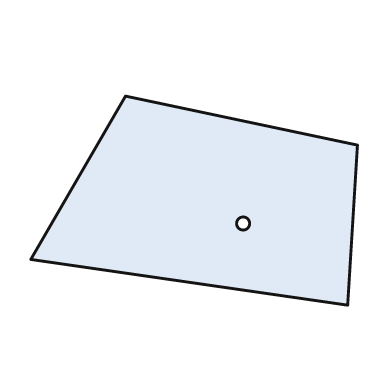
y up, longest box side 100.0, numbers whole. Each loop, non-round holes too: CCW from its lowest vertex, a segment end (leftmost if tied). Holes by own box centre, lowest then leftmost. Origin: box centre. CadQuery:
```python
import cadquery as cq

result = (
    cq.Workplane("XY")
    .moveTo(47.0, -32.0)
    .lineTo(50.0, 17.0)
    .lineTo(-21.0, 32.0)
    .lineTo(-50.0, -18.0)
    .close()
    .moveTo(15.0, -7.0)
    .circle(2.0)
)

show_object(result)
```